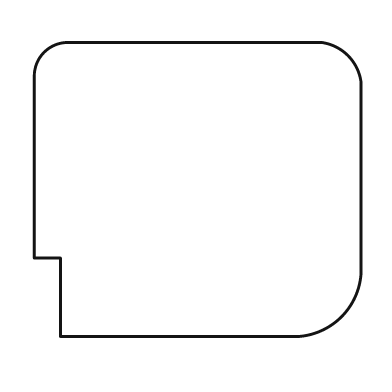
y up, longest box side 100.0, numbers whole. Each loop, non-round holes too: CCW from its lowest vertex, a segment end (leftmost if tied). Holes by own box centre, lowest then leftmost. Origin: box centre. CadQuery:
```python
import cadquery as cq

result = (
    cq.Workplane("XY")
    .moveTo(-42.0, -45.0)
    .lineTo(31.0, -45.0)
    .threePointArc((44.0, -39.0), (50.0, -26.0))
    .lineTo(50.0, 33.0)
    .threePointArc((46.0, 41.0), (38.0, 45.0))
    .lineTo(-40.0, 45.0)
    .threePointArc((-47.0, 42.0), (-50.0, 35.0))
    .lineTo(-50.0, -21.0)
    .lineTo(-42.0, -21.0)
    .close()
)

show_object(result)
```